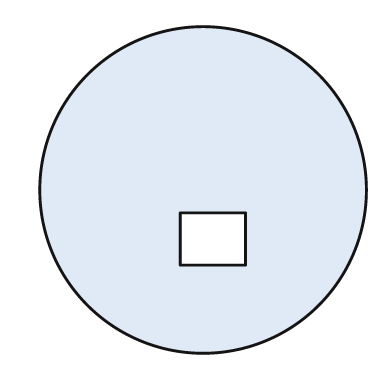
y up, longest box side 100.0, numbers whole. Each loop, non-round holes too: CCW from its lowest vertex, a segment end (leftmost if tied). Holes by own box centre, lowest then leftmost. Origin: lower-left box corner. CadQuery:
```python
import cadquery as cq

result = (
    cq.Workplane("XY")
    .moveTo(50.0, 50.0)
    .circle(50.0)
    .moveTo(43.0, 27.0)
    .lineTo(63.0, 27.0)
    .lineTo(63.0, 43.0)
    .lineTo(43.0, 43.0)
    .close()
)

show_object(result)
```